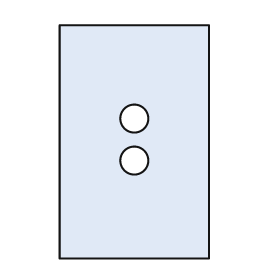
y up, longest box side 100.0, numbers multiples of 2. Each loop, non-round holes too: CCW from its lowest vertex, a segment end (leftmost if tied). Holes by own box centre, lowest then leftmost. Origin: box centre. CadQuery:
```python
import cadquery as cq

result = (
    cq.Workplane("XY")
    .moveTo(-32.0, -50.0)
    .lineTo(32.0, -50.0)
    .lineTo(32.0, 50.0)
    .lineTo(-32.0, 50.0)
    .close()
    .moveTo(0.0, -8.0)
    .circle(6.0)
    .moveTo(0.0, 10.0)
    .circle(6.0)
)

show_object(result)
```